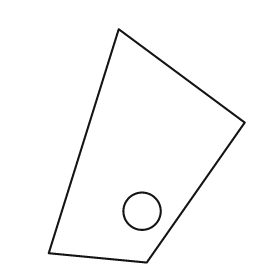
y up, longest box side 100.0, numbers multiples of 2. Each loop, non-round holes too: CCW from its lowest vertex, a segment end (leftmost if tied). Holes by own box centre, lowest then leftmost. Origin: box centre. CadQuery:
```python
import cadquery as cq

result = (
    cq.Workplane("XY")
    .moveTo(0.0, -50.0)
    .lineTo(42.0, 10.0)
    .lineTo(-12.0, 50.0)
    .lineTo(-42.0, -46.0)
    .close()
    .moveTo(-2.0, -28.0)
    .circle(8.0)
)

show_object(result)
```